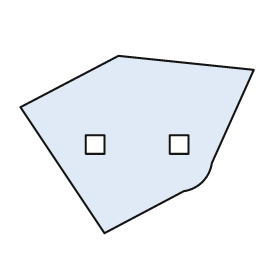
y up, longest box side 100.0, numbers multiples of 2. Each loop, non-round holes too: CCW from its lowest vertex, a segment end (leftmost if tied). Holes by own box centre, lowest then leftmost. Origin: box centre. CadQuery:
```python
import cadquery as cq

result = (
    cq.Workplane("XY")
    .moveTo(-14.0, -38.0)
    .lineTo(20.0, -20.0)
    .threePointArc((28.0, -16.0), (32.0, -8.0))
    .lineTo(50.0, 32.0)
    .lineTo(-8.0, 38.0)
    .lineTo(-50.0, 16.0)
    .close()
    .moveTo(-22.0, -4.0)
    .lineTo(-14.0, -4.0)
    .lineTo(-14.0, 4.0)
    .lineTo(-22.0, 4.0)
    .close()
    .moveTo(14.0, -4.0)
    .lineTo(22.0, -4.0)
    .lineTo(22.0, 4.0)
    .lineTo(14.0, 4.0)
    .close()
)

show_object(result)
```